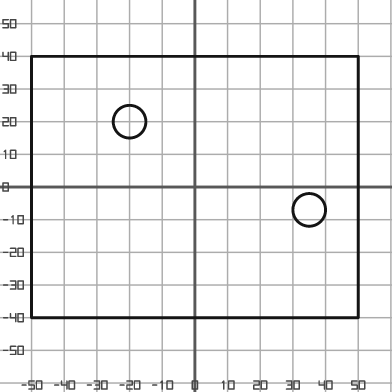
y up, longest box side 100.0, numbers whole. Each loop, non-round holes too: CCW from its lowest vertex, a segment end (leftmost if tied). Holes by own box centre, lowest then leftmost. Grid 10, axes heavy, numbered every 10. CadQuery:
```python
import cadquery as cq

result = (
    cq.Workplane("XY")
    .moveTo(-50.0, -40.0)
    .lineTo(50.0, -40.0)
    .lineTo(50.0, 40.0)
    .lineTo(-50.0, 40.0)
    .close()
    .moveTo(35.0, -7.0)
    .circle(5.0)
    .moveTo(-20.0, 20.0)
    .circle(5.0)
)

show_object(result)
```